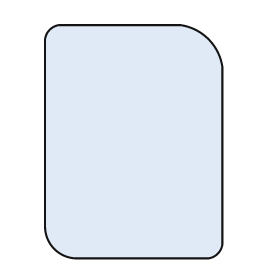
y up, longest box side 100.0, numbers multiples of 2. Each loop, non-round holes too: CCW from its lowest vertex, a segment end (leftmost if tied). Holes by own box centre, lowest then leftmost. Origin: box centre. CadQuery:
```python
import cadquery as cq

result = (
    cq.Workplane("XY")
    .moveTo(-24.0, -50.0)
    .lineTo(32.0, -50.0)
    .threePointArc((36.0, -48.0), (38.0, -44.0))
    .lineTo(38.0, 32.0)
    .threePointArc((32.0, 44.0), (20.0, 50.0))
    .lineTo(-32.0, 50.0)
    .threePointArc((-36.0, 48.0), (-38.0, 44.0))
    .lineTo(-38.0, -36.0)
    .threePointArc((-34.0, -46.0), (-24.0, -50.0))
    .close()
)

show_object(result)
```